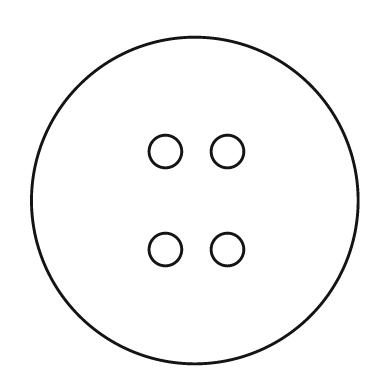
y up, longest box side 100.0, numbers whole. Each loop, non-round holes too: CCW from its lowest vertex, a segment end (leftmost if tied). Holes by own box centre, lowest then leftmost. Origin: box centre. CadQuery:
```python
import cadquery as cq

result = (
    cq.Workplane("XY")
    .moveTo(0.0, 0.0)
    .circle(50.0)
    .moveTo(-9.0, -15.0)
    .circle(5.0)
    .moveTo(10.0, -15.0)
    .circle(5.0)
    .moveTo(-9.0, 15.0)
    .circle(5.0)
    .moveTo(10.0, 15.0)
    .circle(5.0)
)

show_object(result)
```